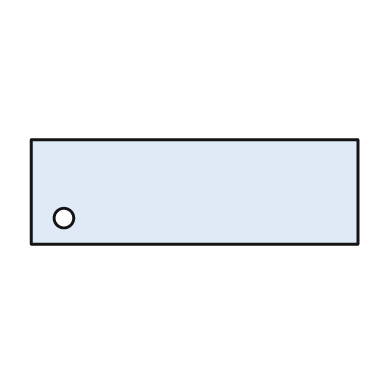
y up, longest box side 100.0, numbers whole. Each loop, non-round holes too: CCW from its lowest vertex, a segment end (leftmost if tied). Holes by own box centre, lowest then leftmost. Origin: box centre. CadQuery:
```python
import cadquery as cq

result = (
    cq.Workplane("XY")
    .moveTo(-50.0, -16.0)
    .lineTo(50.0, -16.0)
    .lineTo(50.0, 16.0)
    .lineTo(-50.0, 16.0)
    .close()
    .moveTo(-40.0, -8.0)
    .circle(3.0)
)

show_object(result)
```